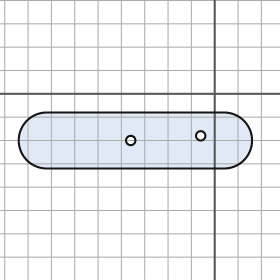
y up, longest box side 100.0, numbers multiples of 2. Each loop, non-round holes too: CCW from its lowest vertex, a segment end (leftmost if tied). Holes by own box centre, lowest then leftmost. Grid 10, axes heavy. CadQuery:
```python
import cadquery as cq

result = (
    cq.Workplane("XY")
    .moveTo(-72.0, -32.0)
    .lineTo(4.0, -32.0)
    .threePointArc((16.0, -20.0), (4.0, -8.0))
    .lineTo(-72.0, -8.0)
    .threePointArc((-84.0, -20.0), (-72.0, -32.0))
    .close()
    .moveTo(-36.0, -20.0)
    .circle(2.0)
    .moveTo(-6.0, -18.0)
    .circle(2.0)
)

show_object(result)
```